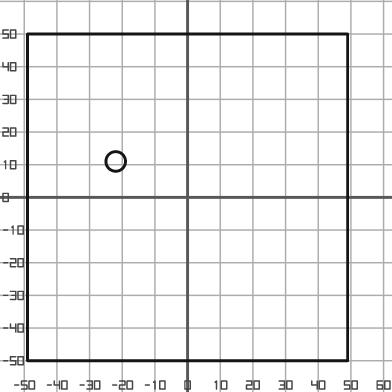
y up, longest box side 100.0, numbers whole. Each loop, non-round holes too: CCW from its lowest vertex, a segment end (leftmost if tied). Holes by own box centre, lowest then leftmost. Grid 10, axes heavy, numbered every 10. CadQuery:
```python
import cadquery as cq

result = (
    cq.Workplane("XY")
    .moveTo(-49.0, -50.0)
    .lineTo(49.0, -50.0)
    .lineTo(49.0, 50.0)
    .lineTo(-49.0, 50.0)
    .close()
    .moveTo(-22.0, 11.0)
    .circle(3.0)
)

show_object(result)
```